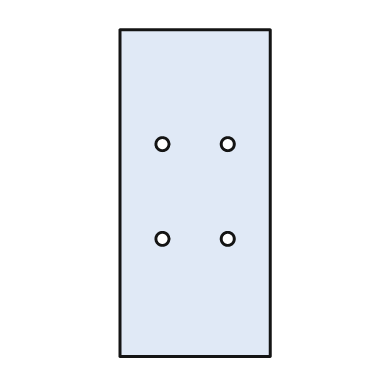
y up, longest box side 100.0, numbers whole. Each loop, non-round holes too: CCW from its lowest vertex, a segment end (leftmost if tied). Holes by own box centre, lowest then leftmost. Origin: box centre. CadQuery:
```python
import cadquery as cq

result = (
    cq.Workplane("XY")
    .moveTo(-23.0, -50.0)
    .lineTo(23.0, -50.0)
    .lineTo(23.0, 50.0)
    .lineTo(-23.0, 50.0)
    .close()
    .moveTo(-10.0, -14.0)
    .circle(2.0)
    .moveTo(10.0, -14.0)
    .circle(2.0)
    .moveTo(-10.0, 15.0)
    .circle(2.0)
    .moveTo(10.0, 15.0)
    .circle(2.0)
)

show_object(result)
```